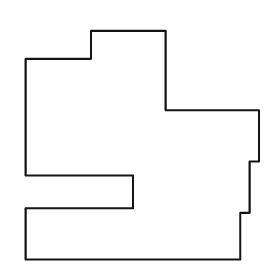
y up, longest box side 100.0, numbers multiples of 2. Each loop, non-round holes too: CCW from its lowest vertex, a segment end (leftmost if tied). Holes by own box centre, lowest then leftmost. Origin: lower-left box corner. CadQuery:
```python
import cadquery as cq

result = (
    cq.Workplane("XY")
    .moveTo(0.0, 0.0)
    .lineTo(92.0, 0.0)
    .lineTo(92.0, 20.0)
    .lineTo(96.0, 20.0)
    .lineTo(96.0, 42.0)
    .lineTo(100.0, 42.0)
    .lineTo(100.0, 64.0)
    .lineTo(60.0, 64.0)
    .lineTo(60.0, 98.0)
    .lineTo(28.0, 98.0)
    .lineTo(28.0, 86.0)
    .lineTo(0.0, 86.0)
    .lineTo(0.0, 36.0)
    .lineTo(46.0, 36.0)
    .lineTo(46.0, 22.0)
    .lineTo(0.0, 22.0)
    .close()
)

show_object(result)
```